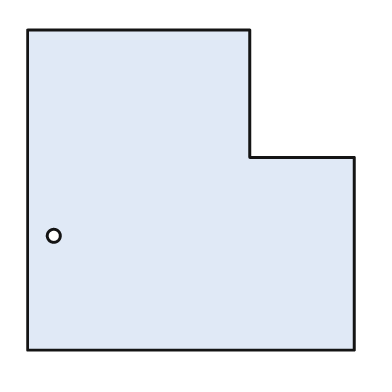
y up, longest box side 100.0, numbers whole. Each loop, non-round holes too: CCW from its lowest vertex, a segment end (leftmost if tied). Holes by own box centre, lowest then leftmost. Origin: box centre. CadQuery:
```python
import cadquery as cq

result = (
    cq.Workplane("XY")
    .moveTo(-50.0, -49.0)
    .lineTo(50.0, -49.0)
    .lineTo(50.0, 10.0)
    .lineTo(18.0, 10.0)
    .lineTo(18.0, 49.0)
    .lineTo(-50.0, 49.0)
    .close()
    .moveTo(-42.0, -14.0)
    .circle(2.0)
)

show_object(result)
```